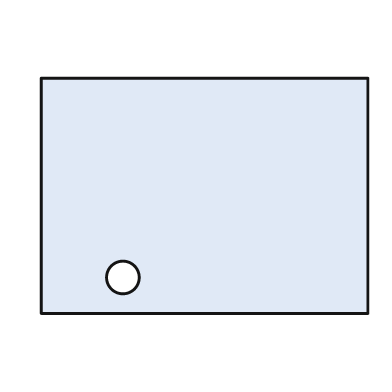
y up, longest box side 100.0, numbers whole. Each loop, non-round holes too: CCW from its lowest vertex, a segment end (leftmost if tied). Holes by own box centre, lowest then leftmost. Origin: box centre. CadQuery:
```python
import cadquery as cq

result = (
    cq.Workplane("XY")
    .moveTo(-50.0, -36.0)
    .lineTo(50.0, -36.0)
    .lineTo(50.0, 36.0)
    .lineTo(-50.0, 36.0)
    .close()
    .moveTo(-25.0, -25.0)
    .circle(5.0)
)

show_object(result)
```